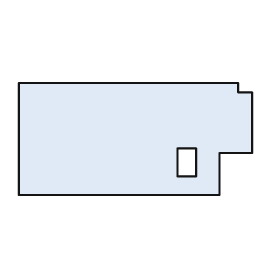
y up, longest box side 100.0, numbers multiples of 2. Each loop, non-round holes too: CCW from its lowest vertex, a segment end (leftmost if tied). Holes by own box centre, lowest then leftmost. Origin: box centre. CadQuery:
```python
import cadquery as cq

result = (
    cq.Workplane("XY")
    .moveTo(-50.0, -24.0)
    .lineTo(36.0, -24.0)
    .lineTo(36.0, -6.0)
    .lineTo(50.0, -6.0)
    .lineTo(50.0, 20.0)
    .lineTo(44.0, 20.0)
    .lineTo(44.0, 24.0)
    .lineTo(-50.0, 24.0)
    .close()
    .moveTo(18.0, -16.0)
    .lineTo(26.0, -16.0)
    .lineTo(26.0, -4.0)
    .lineTo(18.0, -4.0)
    .close()
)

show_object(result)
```